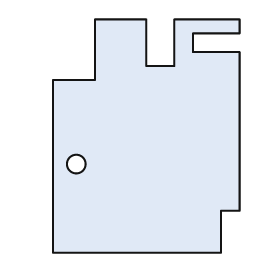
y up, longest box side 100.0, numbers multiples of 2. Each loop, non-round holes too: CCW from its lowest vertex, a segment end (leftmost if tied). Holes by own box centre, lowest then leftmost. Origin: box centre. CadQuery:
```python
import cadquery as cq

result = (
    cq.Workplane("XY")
    .moveTo(-40.0, -50.0)
    .lineTo(32.0, -50.0)
    .lineTo(32.0, -32.0)
    .lineTo(40.0, -32.0)
    .lineTo(40.0, 36.0)
    .lineTo(20.0, 36.0)
    .lineTo(20.0, 44.0)
    .lineTo(40.0, 44.0)
    .lineTo(40.0, 50.0)
    .lineTo(12.0, 50.0)
    .lineTo(12.0, 30.0)
    .lineTo(0.0, 30.0)
    .lineTo(0.0, 50.0)
    .lineTo(-22.0, 50.0)
    .lineTo(-22.0, 24.0)
    .lineTo(-40.0, 24.0)
    .close()
    .moveTo(-30.0, -12.0)
    .circle(4.0)
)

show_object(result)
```